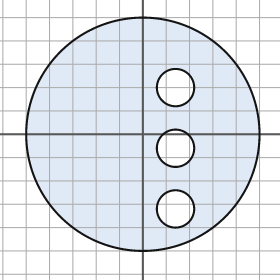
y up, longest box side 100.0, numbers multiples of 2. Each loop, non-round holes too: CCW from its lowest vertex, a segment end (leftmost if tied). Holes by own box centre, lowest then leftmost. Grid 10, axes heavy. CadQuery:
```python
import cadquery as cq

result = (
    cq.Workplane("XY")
    .moveTo(0.0, 0.0)
    .circle(50.0)
    .moveTo(14.0, -32.0)
    .circle(8.0)
    .moveTo(14.0, -6.0)
    .circle(8.0)
    .moveTo(14.0, 20.0)
    .circle(8.0)
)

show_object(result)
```